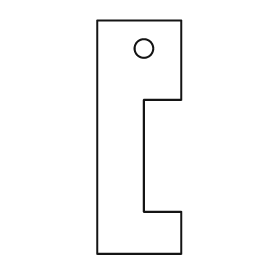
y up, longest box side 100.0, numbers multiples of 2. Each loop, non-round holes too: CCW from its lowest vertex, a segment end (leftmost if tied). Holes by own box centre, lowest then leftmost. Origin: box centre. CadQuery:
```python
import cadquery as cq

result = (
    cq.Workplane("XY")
    .moveTo(-18.0, -50.0)
    .lineTo(18.0, -50.0)
    .lineTo(18.0, -32.0)
    .lineTo(2.0, -32.0)
    .lineTo(2.0, 16.0)
    .lineTo(18.0, 16.0)
    .lineTo(18.0, 50.0)
    .lineTo(-18.0, 50.0)
    .close()
    .moveTo(2.0, 38.0)
    .circle(4.0)
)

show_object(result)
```